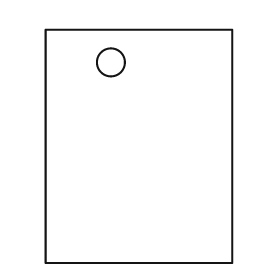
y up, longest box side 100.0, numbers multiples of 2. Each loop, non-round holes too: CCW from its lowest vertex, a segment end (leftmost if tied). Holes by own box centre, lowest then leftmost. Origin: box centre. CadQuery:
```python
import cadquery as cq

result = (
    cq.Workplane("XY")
    .moveTo(-40.0, -50.0)
    .lineTo(40.0, -50.0)
    .lineTo(40.0, 50.0)
    .lineTo(-40.0, 50.0)
    .close()
    .moveTo(-12.0, 36.0)
    .circle(6.0)
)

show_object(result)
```